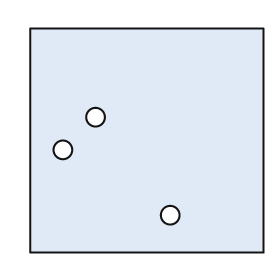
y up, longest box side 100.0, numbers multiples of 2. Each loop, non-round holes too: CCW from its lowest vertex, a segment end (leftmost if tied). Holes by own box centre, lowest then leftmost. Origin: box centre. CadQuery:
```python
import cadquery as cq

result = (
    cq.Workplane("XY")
    .moveTo(-50.0, -48.0)
    .lineTo(50.0, -48.0)
    .lineTo(50.0, 48.0)
    .lineTo(-50.0, 48.0)
    .close()
    .moveTo(10.0, -32.0)
    .circle(4.0)
    .moveTo(-36.0, -4.0)
    .circle(4.0)
    .moveTo(-22.0, 10.0)
    .circle(4.0)
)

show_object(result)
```